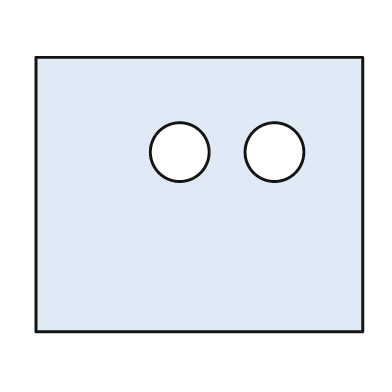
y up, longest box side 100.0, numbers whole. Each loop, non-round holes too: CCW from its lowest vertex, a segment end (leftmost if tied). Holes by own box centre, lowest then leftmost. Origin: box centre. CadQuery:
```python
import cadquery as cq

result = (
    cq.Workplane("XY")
    .moveTo(-50.0, -42.0)
    .lineTo(50.0, -42.0)
    .lineTo(50.0, 42.0)
    .lineTo(-50.0, 42.0)
    .close()
    .moveTo(-6.0, 13.0)
    .circle(9.0)
    .moveTo(23.0, 13.0)
    .circle(9.0)
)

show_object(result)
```